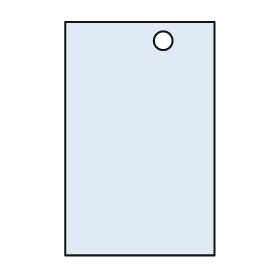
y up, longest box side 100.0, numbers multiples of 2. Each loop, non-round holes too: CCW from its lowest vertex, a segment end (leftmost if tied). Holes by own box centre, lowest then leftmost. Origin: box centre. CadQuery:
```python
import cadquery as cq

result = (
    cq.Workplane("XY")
    .moveTo(-32.0, -50.0)
    .lineTo(32.0, -50.0)
    .lineTo(32.0, 50.0)
    .lineTo(-32.0, 50.0)
    .close()
    .moveTo(10.0, 42.0)
    .circle(4.0)
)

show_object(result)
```